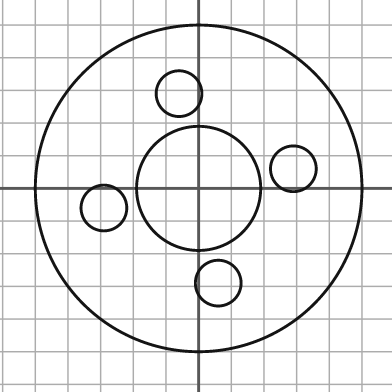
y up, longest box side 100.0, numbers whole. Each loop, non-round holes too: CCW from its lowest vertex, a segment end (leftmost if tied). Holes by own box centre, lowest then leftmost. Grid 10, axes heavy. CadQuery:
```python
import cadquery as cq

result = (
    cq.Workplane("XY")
    .moveTo(0.0, 0.0)
    .circle(50.0)
    .moveTo(6.0, -29.0)
    .circle(7.0)
    .moveTo(-29.0, -6.0)
    .circle(7.0)
    .moveTo(0.0, 0.0)
    .circle(19.0)
    .moveTo(29.0, 6.0)
    .circle(7.0)
    .moveTo(-6.0, 29.0)
    .circle(7.0)
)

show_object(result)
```